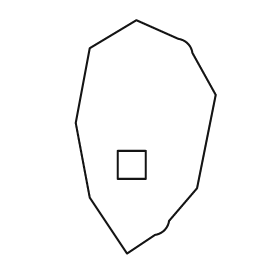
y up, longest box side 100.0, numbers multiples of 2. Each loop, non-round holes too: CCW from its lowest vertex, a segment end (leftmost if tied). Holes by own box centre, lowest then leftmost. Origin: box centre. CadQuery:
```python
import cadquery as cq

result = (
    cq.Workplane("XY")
    .moveTo(-8.0, -50.0)
    .lineTo(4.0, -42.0)
    .threePointArc((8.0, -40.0), (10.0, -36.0))
    .lineTo(22.0, -22.0)
    .lineTo(30.0, 18.0)
    .lineTo(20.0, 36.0)
    .threePointArc((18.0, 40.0), (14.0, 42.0))
    .lineTo(-4.0, 50.0)
    .lineTo(-24.0, 38.0)
    .lineTo(-30.0, 6.0)
    .lineTo(-24.0, -26.0)
    .close()
    .moveTo(-12.0, -18.0)
    .lineTo(0.0, -18.0)
    .lineTo(0.0, -6.0)
    .lineTo(-12.0, -6.0)
    .close()
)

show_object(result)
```